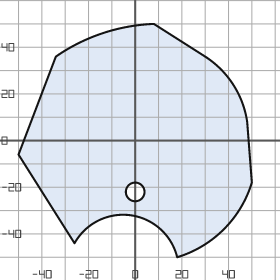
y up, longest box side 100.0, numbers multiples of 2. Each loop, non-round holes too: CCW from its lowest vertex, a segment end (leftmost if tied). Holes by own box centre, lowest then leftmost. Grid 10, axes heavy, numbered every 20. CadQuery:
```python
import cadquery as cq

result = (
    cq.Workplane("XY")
    .moveTo(18.0, -50.0)
    .threePointArc((38.0, -38.0), (50.0, -18.0))
    .lineTo(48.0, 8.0)
    .threePointArc((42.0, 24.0), (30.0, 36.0))
    .lineTo(8.0, 50.0)
    .threePointArc((-14.0, 46.0), (-34.0, 36.0))
    .lineTo(-50.0, -6.0)
    .lineTo(-26.0, -44.0)
    .threePointArc((-2.0, -32.0), (18.0, -50.0))
    .close()
    .moveTo(0.0, -22.0)
    .circle(4.0)
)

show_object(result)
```